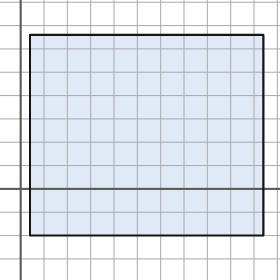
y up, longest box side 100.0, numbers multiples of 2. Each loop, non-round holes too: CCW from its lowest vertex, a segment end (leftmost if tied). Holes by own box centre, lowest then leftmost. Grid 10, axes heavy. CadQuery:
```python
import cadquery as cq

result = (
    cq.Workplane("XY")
    .moveTo(4.0, -20.0)
    .lineTo(104.0, -20.0)
    .lineTo(104.0, 66.0)
    .lineTo(4.0, 66.0)
    .close()
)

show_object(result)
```